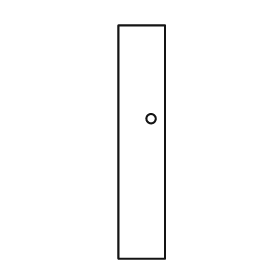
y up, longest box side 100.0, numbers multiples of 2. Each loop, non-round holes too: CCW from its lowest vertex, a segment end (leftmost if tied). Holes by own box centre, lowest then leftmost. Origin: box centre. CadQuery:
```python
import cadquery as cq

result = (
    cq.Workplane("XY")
    .moveTo(-10.0, -50.0)
    .lineTo(10.0, -50.0)
    .lineTo(10.0, 50.0)
    .lineTo(-10.0, 50.0)
    .close()
    .moveTo(4.0, 10.0)
    .circle(2.0)
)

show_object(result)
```